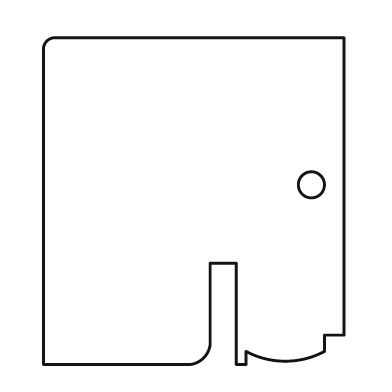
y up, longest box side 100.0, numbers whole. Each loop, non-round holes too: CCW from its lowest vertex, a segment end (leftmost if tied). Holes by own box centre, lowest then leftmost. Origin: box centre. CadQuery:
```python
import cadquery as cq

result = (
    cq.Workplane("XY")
    .moveTo(-46.0, -50.0)
    .lineTo(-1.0, -50.0)
    .threePointArc((3.0, -48.0), (5.0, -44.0))
    .lineTo(5.0, -19.0)
    .lineTo(13.0, -19.0)
    .lineTo(13.0, -50.0)
    .lineTo(16.0, -50.0)
    .lineTo(16.0, -46.0)
    .threePointArc((28.0, -49.0), (40.0, -46.0))
    .lineTo(40.0, -41.0)
    .lineTo(46.0, -41.0)
    .lineTo(46.0, 50.0)
    .lineTo(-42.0, 50.0)
    .threePointArc((-45.0, 49.0), (-46.0, 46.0))
    .close()
    .moveTo(36.0, 5.0)
    .circle(4.0)
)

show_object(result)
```